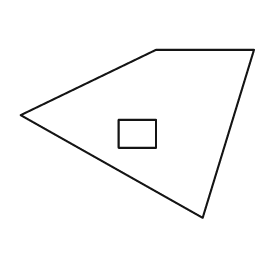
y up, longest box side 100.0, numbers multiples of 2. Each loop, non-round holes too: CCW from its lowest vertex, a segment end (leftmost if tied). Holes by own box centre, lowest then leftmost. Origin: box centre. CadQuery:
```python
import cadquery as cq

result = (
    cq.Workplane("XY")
    .moveTo(28.0, -36.0)
    .lineTo(50.0, 36.0)
    .lineTo(8.0, 36.0)
    .lineTo(-50.0, 8.0)
    .close()
    .moveTo(-8.0, -6.0)
    .lineTo(8.0, -6.0)
    .lineTo(8.0, 6.0)
    .lineTo(-8.0, 6.0)
    .close()
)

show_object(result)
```